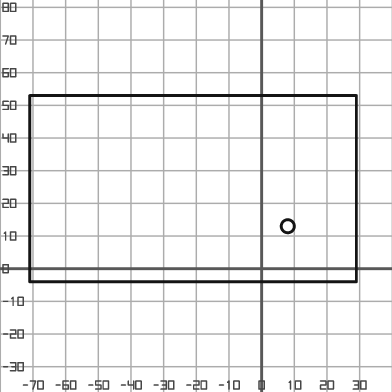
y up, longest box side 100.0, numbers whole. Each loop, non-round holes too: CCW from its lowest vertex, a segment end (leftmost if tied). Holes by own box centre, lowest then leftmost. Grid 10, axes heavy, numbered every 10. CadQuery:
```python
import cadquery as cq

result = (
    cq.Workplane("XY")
    .moveTo(-71.0, -4.0)
    .lineTo(29.0, -4.0)
    .lineTo(29.0, 53.0)
    .lineTo(-71.0, 53.0)
    .close()
    .moveTo(8.0, 13.0)
    .circle(2.0)
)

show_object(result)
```